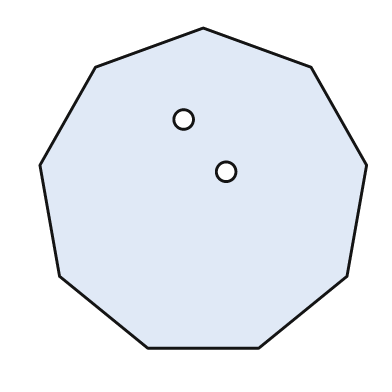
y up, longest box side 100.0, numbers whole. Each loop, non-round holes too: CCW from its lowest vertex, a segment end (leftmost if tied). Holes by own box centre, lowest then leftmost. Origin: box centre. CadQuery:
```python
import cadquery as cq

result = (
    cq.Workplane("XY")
    .moveTo(-17.0, -49.0)
    .lineTo(17.0, -49.0)
    .lineTo(44.0, -27.0)
    .lineTo(50.0, 7.0)
    .lineTo(33.0, 37.0)
    .lineTo(0.0, 49.0)
    .lineTo(-33.0, 37.0)
    .lineTo(-50.0, 7.0)
    .lineTo(-44.0, -27.0)
    .close()
    .moveTo(7.0, 5.0)
    .circle(3.0)
    .moveTo(-6.0, 21.0)
    .circle(3.0)
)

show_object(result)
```